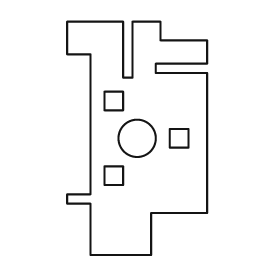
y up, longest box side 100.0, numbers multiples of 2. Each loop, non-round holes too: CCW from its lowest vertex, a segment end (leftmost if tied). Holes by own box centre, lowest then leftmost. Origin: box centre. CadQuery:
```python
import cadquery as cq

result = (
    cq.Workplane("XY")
    .moveTo(-20.0, -50.0)
    .lineTo(6.0, -50.0)
    .lineTo(6.0, -32.0)
    .lineTo(30.0, -32.0)
    .lineTo(30.0, 28.0)
    .lineTo(8.0, 28.0)
    .lineTo(8.0, 32.0)
    .lineTo(30.0, 32.0)
    .lineTo(30.0, 42.0)
    .lineTo(10.0, 42.0)
    .lineTo(10.0, 50.0)
    .lineTo(-2.0, 50.0)
    .lineTo(-2.0, 26.0)
    .lineTo(-6.0, 26.0)
    .lineTo(-6.0, 50.0)
    .lineTo(-30.0, 50.0)
    .lineTo(-30.0, 36.0)
    .lineTo(-20.0, 36.0)
    .lineTo(-20.0, -24.0)
    .lineTo(-30.0, -24.0)
    .lineTo(-30.0, -28.0)
    .lineTo(-20.0, -28.0)
    .close()
    .moveTo(-14.0, -20.0)
    .lineTo(-6.0, -20.0)
    .lineTo(-6.0, -12.0)
    .lineTo(-14.0, -12.0)
    .close()
    .moveTo(0.0, 0.0)
    .circle(8.0)
    .moveTo(14.0, -4.0)
    .lineTo(22.0, -4.0)
    .lineTo(22.0, 4.0)
    .lineTo(14.0, 4.0)
    .close()
    .moveTo(-14.0, 12.0)
    .lineTo(-6.0, 12.0)
    .lineTo(-6.0, 20.0)
    .lineTo(-14.0, 20.0)
    .close()
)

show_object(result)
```